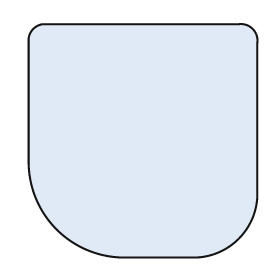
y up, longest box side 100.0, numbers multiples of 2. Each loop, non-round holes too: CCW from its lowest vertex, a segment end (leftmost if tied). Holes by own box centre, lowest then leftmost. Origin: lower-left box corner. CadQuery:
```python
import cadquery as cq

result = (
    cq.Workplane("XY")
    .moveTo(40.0, 0.0)
    .lineTo(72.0, 0.0)
    .threePointArc((90.0, 8.0), (98.0, 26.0))
    .lineTo(98.0, 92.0)
    .threePointArc((96.0, 98.0), (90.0, 100.0))
    .lineTo(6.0, 100.0)
    .threePointArc((2.0, 98.0), (0.0, 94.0))
    .lineTo(0.0, 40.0)
    .threePointArc((12.0, 12.0), (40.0, 0.0))
    .close()
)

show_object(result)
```